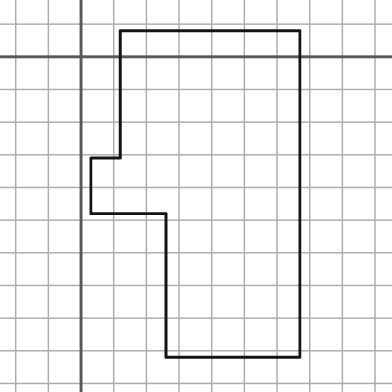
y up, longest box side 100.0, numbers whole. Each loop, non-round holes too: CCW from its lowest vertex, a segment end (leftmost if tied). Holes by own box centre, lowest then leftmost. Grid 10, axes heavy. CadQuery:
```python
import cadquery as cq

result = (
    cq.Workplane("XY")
    .moveTo(26.0, -92.0)
    .lineTo(67.0, -92.0)
    .lineTo(67.0, 8.0)
    .lineTo(12.0, 8.0)
    .lineTo(12.0, -31.0)
    .lineTo(3.0, -31.0)
    .lineTo(3.0, -48.0)
    .lineTo(26.0, -48.0)
    .close()
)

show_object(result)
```